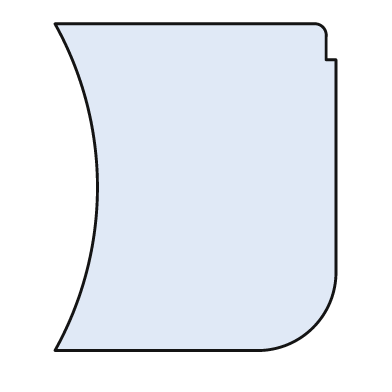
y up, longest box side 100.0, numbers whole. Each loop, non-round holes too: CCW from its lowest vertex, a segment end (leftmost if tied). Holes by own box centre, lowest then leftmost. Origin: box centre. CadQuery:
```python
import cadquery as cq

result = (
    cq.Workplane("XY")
    .moveTo(-43.0, -50.0)
    .lineTo(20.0, -50.0)
    .threePointArc((36.0, -43.0), (43.0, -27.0))
    .lineTo(43.0, 39.0)
    .lineTo(40.0, 39.0)
    .lineTo(40.0, 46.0)
    .threePointArc((39.0, 49.0), (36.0, 50.0))
    .lineTo(-43.0, 50.0)
    .threePointArc((-30.0, 0.0), (-43.0, -50.0))
    .close()
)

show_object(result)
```